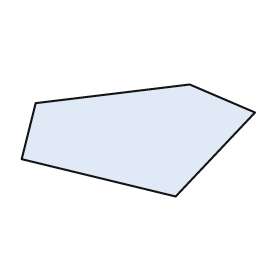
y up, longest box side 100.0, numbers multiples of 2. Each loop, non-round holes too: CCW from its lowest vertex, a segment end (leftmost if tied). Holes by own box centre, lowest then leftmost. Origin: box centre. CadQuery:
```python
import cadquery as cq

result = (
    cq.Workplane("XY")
    .moveTo(16.0, -24.0)
    .lineTo(50.0, 12.0)
    .lineTo(22.0, 24.0)
    .lineTo(-44.0, 16.0)
    .lineTo(-50.0, -8.0)
    .close()
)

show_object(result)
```